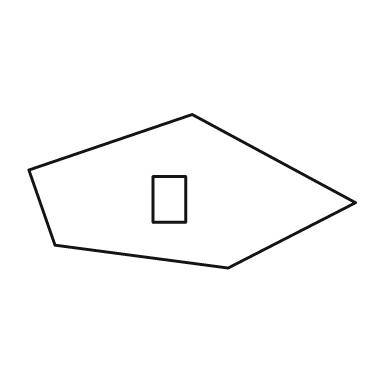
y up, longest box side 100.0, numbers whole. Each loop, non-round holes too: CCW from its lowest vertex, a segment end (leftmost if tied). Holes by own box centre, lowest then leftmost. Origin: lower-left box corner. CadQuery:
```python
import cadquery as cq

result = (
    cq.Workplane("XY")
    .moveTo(61.0, 0.0)
    .lineTo(100.0, 20.0)
    .lineTo(50.0, 47.0)
    .lineTo(0.0, 30.0)
    .lineTo(8.0, 7.0)
    .close()
    .moveTo(38.0, 14.0)
    .lineTo(48.0, 14.0)
    .lineTo(48.0, 28.0)
    .lineTo(38.0, 28.0)
    .close()
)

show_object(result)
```